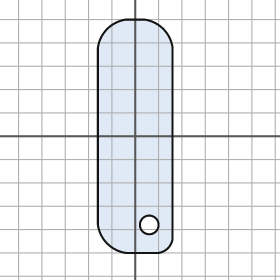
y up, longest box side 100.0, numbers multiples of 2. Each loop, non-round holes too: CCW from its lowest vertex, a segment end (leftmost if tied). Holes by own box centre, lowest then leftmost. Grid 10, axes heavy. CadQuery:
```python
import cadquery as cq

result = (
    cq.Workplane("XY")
    .moveTo(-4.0, -50.0)
    .lineTo(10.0, -50.0)
    .threePointArc((14.0, -48.0), (16.0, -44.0))
    .lineTo(16.0, 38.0)
    .threePointArc((12.0, 46.0), (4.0, 50.0))
    .lineTo(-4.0, 50.0)
    .threePointArc((-12.0, 46.0), (-16.0, 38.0))
    .lineTo(-16.0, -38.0)
    .threePointArc((-12.0, -46.0), (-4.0, -50.0))
    .close()
    .moveTo(6.0, -38.0)
    .circle(4.0)
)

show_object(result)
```